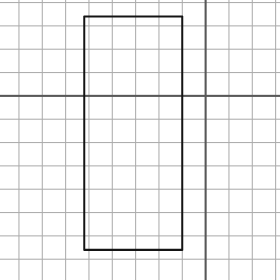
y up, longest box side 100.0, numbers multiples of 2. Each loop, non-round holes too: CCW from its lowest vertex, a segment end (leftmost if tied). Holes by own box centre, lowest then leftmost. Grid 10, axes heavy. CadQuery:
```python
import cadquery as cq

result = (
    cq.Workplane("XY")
    .moveTo(-52.0, -66.0)
    .lineTo(-10.0, -66.0)
    .lineTo(-10.0, 34.0)
    .lineTo(-52.0, 34.0)
    .close()
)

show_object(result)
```